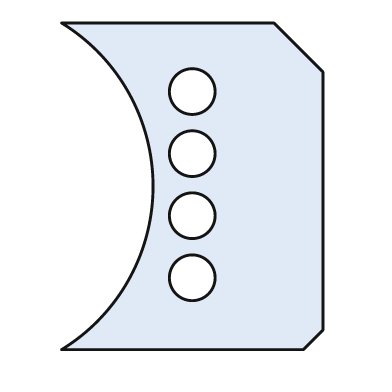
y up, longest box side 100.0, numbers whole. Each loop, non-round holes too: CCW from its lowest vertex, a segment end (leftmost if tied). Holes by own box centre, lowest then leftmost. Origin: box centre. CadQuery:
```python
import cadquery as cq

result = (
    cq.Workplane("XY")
    .moveTo(-40.0, -50.0)
    .lineTo(34.0, -50.0)
    .lineTo(40.0, -44.0)
    .lineTo(40.0, 35.0)
    .lineTo(25.0, 50.0)
    .lineTo(-40.0, 50.0)
    .threePointArc((-12.0, 0.0), (-40.0, -50.0))
    .close()
    .moveTo(0.0, -28.0)
    .circle(7.0)
    .moveTo(0.0, -9.0)
    .circle(7.0)
    .moveTo(0.0, 10.0)
    .circle(7.0)
    .moveTo(0.0, 29.0)
    .circle(7.0)
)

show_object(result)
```